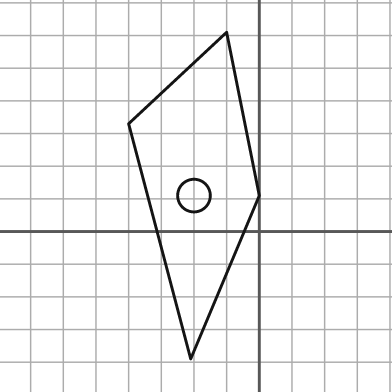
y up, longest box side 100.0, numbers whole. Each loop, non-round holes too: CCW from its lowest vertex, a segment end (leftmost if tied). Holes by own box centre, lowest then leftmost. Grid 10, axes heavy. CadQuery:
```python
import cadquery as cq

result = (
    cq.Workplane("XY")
    .moveTo(-21.0, -39.0)
    .lineTo(0.0, 11.0)
    .lineTo(-10.0, 61.0)
    .lineTo(-40.0, 33.0)
    .close()
    .moveTo(-20.0, 11.0)
    .circle(5.0)
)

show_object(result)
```